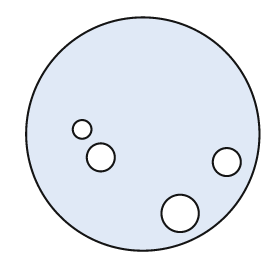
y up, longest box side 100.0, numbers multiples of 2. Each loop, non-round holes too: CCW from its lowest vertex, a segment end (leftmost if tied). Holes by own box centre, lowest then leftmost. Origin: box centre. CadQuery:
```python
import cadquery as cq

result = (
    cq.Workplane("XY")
    .moveTo(0.0, 0.0)
    .circle(50.0)
    .moveTo(16.0, -34.0)
    .circle(8.0)
    .moveTo(36.0, -12.0)
    .circle(6.0)
    .moveTo(-18.0, -10.0)
    .circle(6.0)
    .moveTo(-26.0, 2.0)
    .circle(4.0)
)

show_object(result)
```